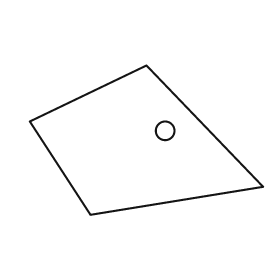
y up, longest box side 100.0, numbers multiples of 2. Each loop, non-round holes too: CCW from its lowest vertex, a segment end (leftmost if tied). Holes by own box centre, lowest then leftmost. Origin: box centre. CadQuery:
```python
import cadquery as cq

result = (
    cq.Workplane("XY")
    .moveTo(-24.0, -32.0)
    .lineTo(50.0, -20.0)
    .lineTo(0.0, 32.0)
    .lineTo(-50.0, 8.0)
    .close()
    .moveTo(8.0, 4.0)
    .circle(4.0)
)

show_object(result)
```